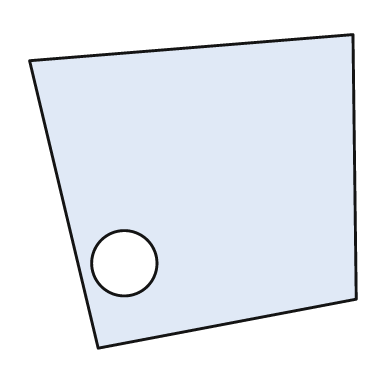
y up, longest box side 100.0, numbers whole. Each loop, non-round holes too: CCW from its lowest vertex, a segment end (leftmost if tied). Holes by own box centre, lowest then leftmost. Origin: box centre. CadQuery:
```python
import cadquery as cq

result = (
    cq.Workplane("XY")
    .moveTo(-29.0, -48.0)
    .lineTo(50.0, -33.0)
    .lineTo(49.0, 48.0)
    .lineTo(-50.0, 40.0)
    .close()
    .moveTo(-21.0, -22.0)
    .circle(10.0)
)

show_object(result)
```